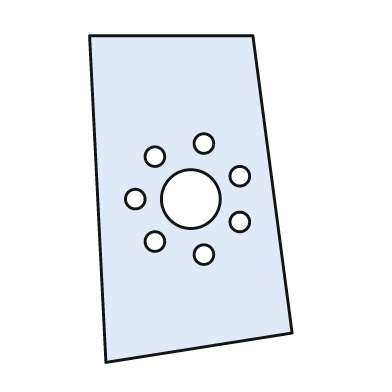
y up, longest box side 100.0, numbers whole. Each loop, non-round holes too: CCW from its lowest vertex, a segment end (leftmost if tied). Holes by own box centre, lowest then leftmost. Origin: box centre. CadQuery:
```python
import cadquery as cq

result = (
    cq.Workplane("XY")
    .moveTo(-26.0, -50.0)
    .lineTo(31.0, -41.0)
    .lineTo(19.0, 50.0)
    .lineTo(-31.0, 50.0)
    .close()
    .moveTo(4.0, -17.0)
    .circle(3.0)
    .moveTo(-11.0, -13.0)
    .circle(3.0)
    .moveTo(15.0, -7.0)
    .circle(3.0)
    .moveTo(-17.0, 0.0)
    .circle(3.0)
    .moveTo(0.0, 0.0)
    .circle(9.0)
    .moveTo(15.0, 7.0)
    .circle(3.0)
    .moveTo(-11.0, 13.0)
    .circle(3.0)
    .moveTo(4.0, 17.0)
    .circle(3.0)
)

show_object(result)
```